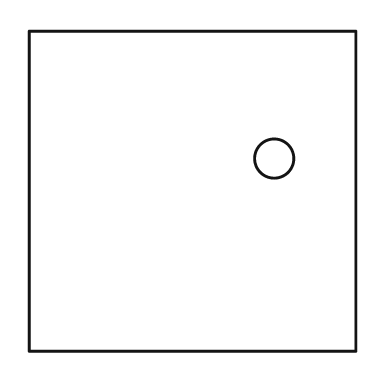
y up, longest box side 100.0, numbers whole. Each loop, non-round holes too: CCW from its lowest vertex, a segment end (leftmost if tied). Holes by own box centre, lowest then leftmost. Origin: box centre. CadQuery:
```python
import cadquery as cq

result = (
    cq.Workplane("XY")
    .moveTo(-50.0, -49.0)
    .lineTo(50.0, -49.0)
    .lineTo(50.0, 49.0)
    .lineTo(-50.0, 49.0)
    .close()
    .moveTo(25.0, 10.0)
    .circle(6.0)
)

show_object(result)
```